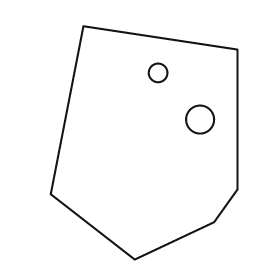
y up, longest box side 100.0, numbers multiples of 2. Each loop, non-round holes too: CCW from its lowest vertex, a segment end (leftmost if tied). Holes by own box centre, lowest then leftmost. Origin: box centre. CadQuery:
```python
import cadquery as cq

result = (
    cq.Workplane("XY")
    .moveTo(-4.0, -50.0)
    .lineTo(30.0, -34.0)
    .lineTo(40.0, -20.0)
    .lineTo(40.0, 40.0)
    .lineTo(-26.0, 50.0)
    .lineTo(-40.0, -22.0)
    .close()
    .moveTo(24.0, 10.0)
    .circle(6.0)
    .moveTo(6.0, 30.0)
    .circle(4.0)
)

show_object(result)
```